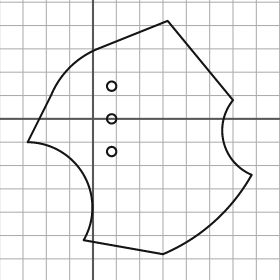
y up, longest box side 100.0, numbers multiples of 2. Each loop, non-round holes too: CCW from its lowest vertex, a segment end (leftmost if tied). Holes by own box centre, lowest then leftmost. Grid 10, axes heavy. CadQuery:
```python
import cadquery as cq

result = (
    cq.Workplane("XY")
    .moveTo(30.0, -58.0)
    .threePointArc((52.0, -44.0), (68.0, -24.0))
    .threePointArc((56.0, -10.0), (60.0, 8.0))
    .lineTo(32.0, 42.0)
    .lineTo(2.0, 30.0)
    .threePointArc((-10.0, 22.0), (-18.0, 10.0))
    .lineTo(-28.0, -10.0)
    .threePointArc((-4.0, -24.0), (-4.0, -52.0))
    .close()
    .moveTo(8.0, -14.0)
    .circle(2.0)
    .moveTo(8.0, 0.0)
    .circle(2.0)
    .moveTo(8.0, 14.0)
    .circle(2.0)
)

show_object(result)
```